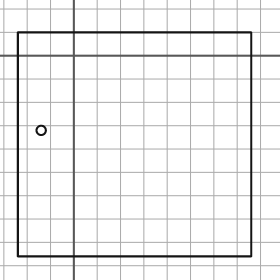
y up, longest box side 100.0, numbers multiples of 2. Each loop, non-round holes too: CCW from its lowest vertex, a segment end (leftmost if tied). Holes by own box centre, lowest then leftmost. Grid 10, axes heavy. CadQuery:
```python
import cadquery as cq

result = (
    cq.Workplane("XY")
    .moveTo(-24.0, -86.0)
    .lineTo(76.0, -86.0)
    .lineTo(76.0, 10.0)
    .lineTo(-24.0, 10.0)
    .close()
    .moveTo(-14.0, -32.0)
    .circle(2.0)
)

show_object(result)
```